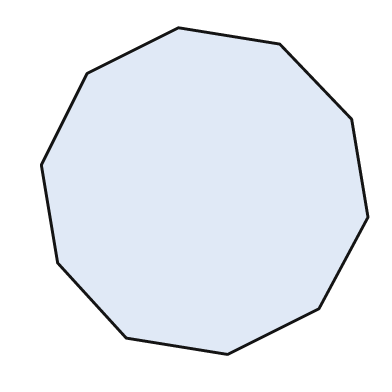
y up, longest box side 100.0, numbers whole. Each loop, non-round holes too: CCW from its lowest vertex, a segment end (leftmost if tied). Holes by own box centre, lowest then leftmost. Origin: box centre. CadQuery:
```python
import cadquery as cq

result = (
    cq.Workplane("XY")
    .moveTo(7.0, -50.0)
    .lineTo(35.0, -36.0)
    .lineTo(50.0, -8.0)
    .lineTo(45.0, 22.0)
    .lineTo(23.0, 45.0)
    .lineTo(-8.0, 50.0)
    .lineTo(-36.0, 36.0)
    .lineTo(-50.0, 8.0)
    .lineTo(-45.0, -22.0)
    .lineTo(-24.0, -45.0)
    .close()
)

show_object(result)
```